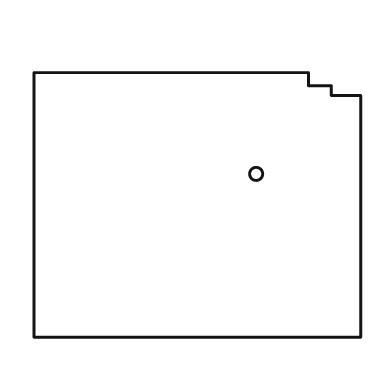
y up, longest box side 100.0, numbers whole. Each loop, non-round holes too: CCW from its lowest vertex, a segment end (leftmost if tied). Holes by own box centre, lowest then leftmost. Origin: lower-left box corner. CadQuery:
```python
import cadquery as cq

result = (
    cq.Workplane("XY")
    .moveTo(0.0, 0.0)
    .lineTo(100.0, 0.0)
    .lineTo(100.0, 74.0)
    .lineTo(91.0, 74.0)
    .lineTo(91.0, 77.0)
    .lineTo(84.0, 77.0)
    .lineTo(84.0, 81.0)
    .lineTo(0.0, 81.0)
    .close()
    .moveTo(68.0, 50.0)
    .circle(2.0)
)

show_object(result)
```